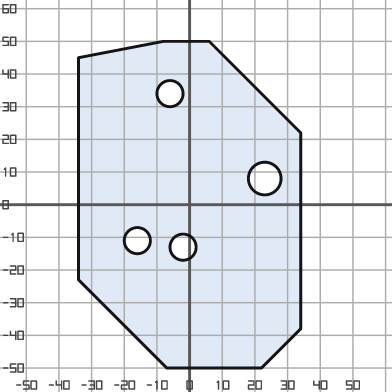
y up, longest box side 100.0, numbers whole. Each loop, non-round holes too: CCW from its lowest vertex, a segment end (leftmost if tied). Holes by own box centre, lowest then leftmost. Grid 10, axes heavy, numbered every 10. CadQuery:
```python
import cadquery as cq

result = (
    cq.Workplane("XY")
    .moveTo(-7.0, -50.0)
    .lineTo(22.0, -50.0)
    .lineTo(34.0, -38.0)
    .lineTo(34.0, 22.0)
    .lineTo(6.0, 50.0)
    .lineTo(-8.0, 50.0)
    .lineTo(-34.0, 45.0)
    .lineTo(-34.0, -23.0)
    .close()
    .moveTo(-2.0, -13.0)
    .circle(4.0)
    .moveTo(-16.0, -11.0)
    .circle(4.0)
    .moveTo(23.0, 8.0)
    .circle(5.0)
    .moveTo(-6.0, 34.0)
    .circle(4.0)
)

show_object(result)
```